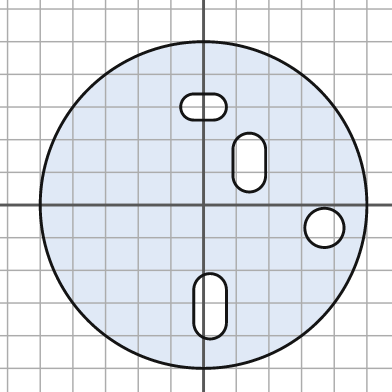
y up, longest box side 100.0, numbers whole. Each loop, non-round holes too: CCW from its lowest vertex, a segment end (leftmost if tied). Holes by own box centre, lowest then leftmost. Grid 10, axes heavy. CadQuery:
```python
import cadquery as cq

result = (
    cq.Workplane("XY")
    .moveTo(0.0, 0.0)
    .circle(50.0)
    .moveTo(-3.0, -36.0)
    .threePointArc((2.0, -41.0), (7.0, -36.0))
    .lineTo(7.0, -26.0)
    .threePointArc((2.0, -21.0), (-3.0, -26.0))
    .close()
    .moveTo(37.0, -7.0)
    .circle(6.0)
    .moveTo(9.0, 9.0)
    .threePointArc((14.0, 4.0), (19.0, 9.0))
    .lineTo(19.0, 17.0)
    .threePointArc((14.0, 22.0), (9.0, 17.0))
    .close()
    .moveTo(-3.0, 26.0)
    .lineTo(3.0, 26.0)
    .threePointArc((7.0, 30.0), (3.0, 34.0))
    .lineTo(-3.0, 34.0)
    .threePointArc((-7.0, 30.0), (-3.0, 26.0))
    .close()
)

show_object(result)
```